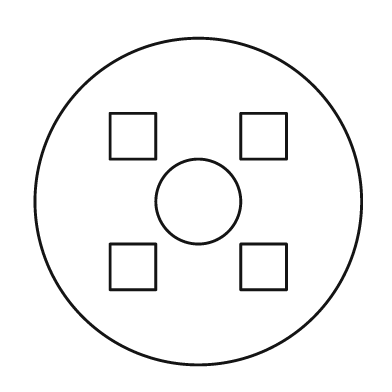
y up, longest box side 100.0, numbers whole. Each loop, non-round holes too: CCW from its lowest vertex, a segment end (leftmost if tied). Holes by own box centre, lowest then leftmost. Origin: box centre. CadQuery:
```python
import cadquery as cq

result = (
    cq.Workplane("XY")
    .moveTo(0.0, 0.0)
    .circle(50.0)
    .moveTo(-27.0, -27.0)
    .lineTo(-13.0, -27.0)
    .lineTo(-13.0, -13.0)
    .lineTo(-27.0, -13.0)
    .close()
    .moveTo(13.0, -27.0)
    .lineTo(27.0, -27.0)
    .lineTo(27.0, -13.0)
    .lineTo(13.0, -13.0)
    .close()
    .moveTo(0.0, 0.0)
    .circle(13.0)
    .moveTo(-27.0, 13.0)
    .lineTo(-13.0, 13.0)
    .lineTo(-13.0, 27.0)
    .lineTo(-27.0, 27.0)
    .close()
    .moveTo(13.0, 13.0)
    .lineTo(27.0, 13.0)
    .lineTo(27.0, 27.0)
    .lineTo(13.0, 27.0)
    .close()
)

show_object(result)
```